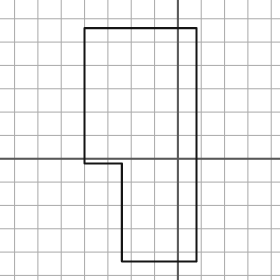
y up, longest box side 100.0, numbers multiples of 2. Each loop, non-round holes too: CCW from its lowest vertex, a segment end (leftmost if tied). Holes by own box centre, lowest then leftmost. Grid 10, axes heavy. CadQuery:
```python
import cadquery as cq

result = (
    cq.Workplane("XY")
    .moveTo(-24.0, -44.0)
    .lineTo(8.0, -44.0)
    .lineTo(8.0, 56.0)
    .lineTo(-40.0, 56.0)
    .lineTo(-40.0, -2.0)
    .lineTo(-24.0, -2.0)
    .close()
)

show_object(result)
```